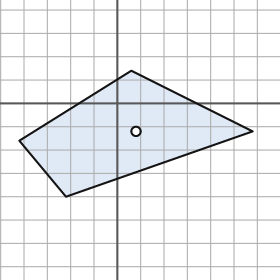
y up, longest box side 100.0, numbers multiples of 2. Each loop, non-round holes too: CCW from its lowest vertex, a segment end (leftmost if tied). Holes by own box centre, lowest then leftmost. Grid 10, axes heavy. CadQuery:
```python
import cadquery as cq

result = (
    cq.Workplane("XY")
    .moveTo(-22.0, -40.0)
    .lineTo(58.0, -12.0)
    .lineTo(6.0, 14.0)
    .lineTo(-42.0, -16.0)
    .close()
    .moveTo(8.0, -12.0)
    .circle(2.0)
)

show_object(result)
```